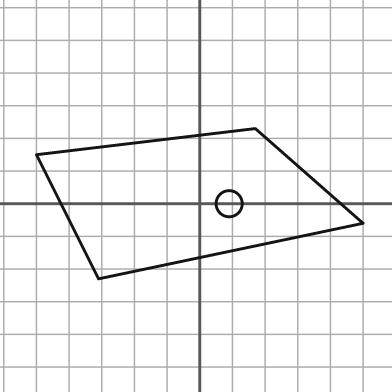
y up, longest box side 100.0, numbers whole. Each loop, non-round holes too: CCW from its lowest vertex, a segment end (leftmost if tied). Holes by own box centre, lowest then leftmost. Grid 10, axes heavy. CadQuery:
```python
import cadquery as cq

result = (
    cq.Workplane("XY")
    .moveTo(-31.0, -23.0)
    .lineTo(50.0, -6.0)
    .lineTo(17.0, 23.0)
    .lineTo(-50.0, 15.0)
    .close()
    .moveTo(9.0, 0.0)
    .circle(4.0)
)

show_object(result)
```